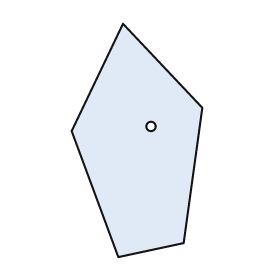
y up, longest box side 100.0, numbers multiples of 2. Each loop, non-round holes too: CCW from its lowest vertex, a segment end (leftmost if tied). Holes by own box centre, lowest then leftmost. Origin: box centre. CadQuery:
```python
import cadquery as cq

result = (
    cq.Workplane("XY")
    .moveTo(-8.0, -50.0)
    .lineTo(20.0, -44.0)
    .lineTo(28.0, 14.0)
    .lineTo(-6.0, 50.0)
    .lineTo(-28.0, 4.0)
    .close()
    .moveTo(6.0, 6.0)
    .circle(2.0)
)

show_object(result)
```